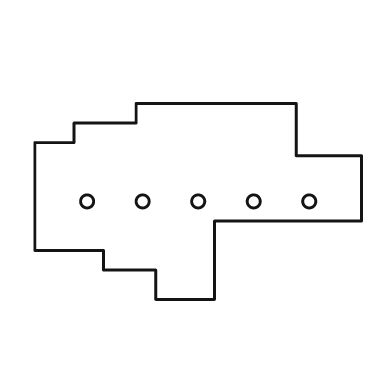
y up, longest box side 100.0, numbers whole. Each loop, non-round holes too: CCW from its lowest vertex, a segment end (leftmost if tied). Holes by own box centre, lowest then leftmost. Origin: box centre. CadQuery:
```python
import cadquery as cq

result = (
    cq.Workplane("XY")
    .moveTo(-13.0, -30.0)
    .lineTo(5.0, -30.0)
    .lineTo(5.0, -6.0)
    .lineTo(50.0, -6.0)
    .lineTo(50.0, 14.0)
    .lineTo(30.0, 14.0)
    .lineTo(30.0, 30.0)
    .lineTo(-19.0, 30.0)
    .lineTo(-19.0, 24.0)
    .lineTo(-38.0, 24.0)
    .lineTo(-38.0, 18.0)
    .lineTo(-50.0, 18.0)
    .lineTo(-50.0, -15.0)
    .lineTo(-29.0, -15.0)
    .lineTo(-29.0, -21.0)
    .lineTo(-13.0, -21.0)
    .close()
    .moveTo(-34.0, 0.0)
    .circle(2.0)
    .moveTo(-17.0, 0.0)
    .circle(2.0)
    .moveTo(0.0, 0.0)
    .circle(2.0)
    .moveTo(17.0, 0.0)
    .circle(2.0)
    .moveTo(34.0, 0.0)
    .circle(2.0)
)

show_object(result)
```